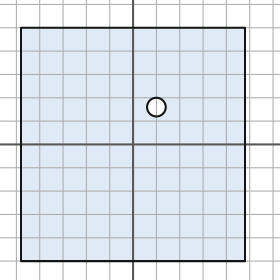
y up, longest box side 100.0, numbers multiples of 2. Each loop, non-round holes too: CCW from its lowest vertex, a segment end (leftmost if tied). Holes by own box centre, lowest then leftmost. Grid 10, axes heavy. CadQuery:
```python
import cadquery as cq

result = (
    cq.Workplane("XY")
    .moveTo(-48.0, -50.0)
    .lineTo(48.0, -50.0)
    .lineTo(48.0, 50.0)
    .lineTo(-48.0, 50.0)
    .close()
    .moveTo(10.0, 16.0)
    .circle(4.0)
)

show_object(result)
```